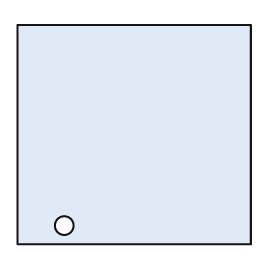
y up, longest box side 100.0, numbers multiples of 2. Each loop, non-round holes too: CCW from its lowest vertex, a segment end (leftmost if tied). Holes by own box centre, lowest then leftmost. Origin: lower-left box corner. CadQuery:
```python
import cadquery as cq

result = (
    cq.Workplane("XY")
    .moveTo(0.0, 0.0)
    .lineTo(100.0, 0.0)
    .lineTo(100.0, 94.0)
    .lineTo(0.0, 94.0)
    .close()
    .moveTo(20.0, 8.0)
    .circle(4.0)
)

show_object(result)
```